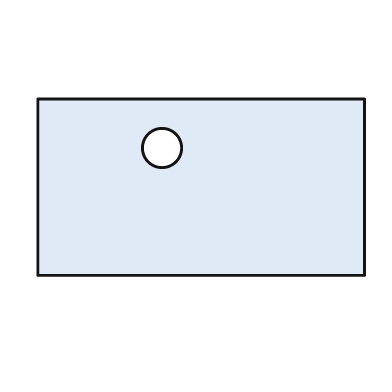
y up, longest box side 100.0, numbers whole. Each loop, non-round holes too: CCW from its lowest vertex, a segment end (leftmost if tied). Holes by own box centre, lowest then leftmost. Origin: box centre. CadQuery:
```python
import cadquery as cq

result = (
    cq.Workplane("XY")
    .moveTo(-50.0, -27.0)
    .lineTo(50.0, -27.0)
    .lineTo(50.0, 27.0)
    .lineTo(-50.0, 27.0)
    .close()
    .moveTo(-12.0, 12.0)
    .circle(6.0)
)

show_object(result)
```